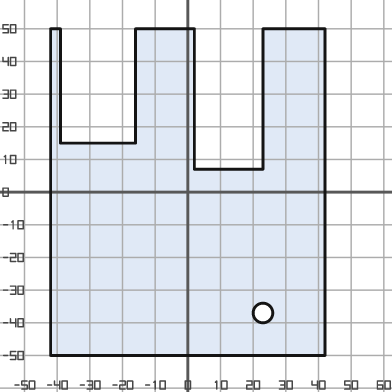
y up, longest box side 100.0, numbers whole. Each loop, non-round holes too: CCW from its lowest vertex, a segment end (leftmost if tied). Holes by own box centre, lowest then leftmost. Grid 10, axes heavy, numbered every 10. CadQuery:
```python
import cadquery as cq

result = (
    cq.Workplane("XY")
    .moveTo(-42.0, -50.0)
    .lineTo(42.0, -50.0)
    .lineTo(42.0, 50.0)
    .lineTo(23.0, 50.0)
    .lineTo(23.0, 7.0)
    .lineTo(2.0, 7.0)
    .lineTo(2.0, 50.0)
    .lineTo(-16.0, 50.0)
    .lineTo(-16.0, 15.0)
    .lineTo(-39.0, 15.0)
    .lineTo(-39.0, 50.0)
    .lineTo(-42.0, 50.0)
    .close()
    .moveTo(23.0, -37.0)
    .circle(3.0)
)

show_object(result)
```